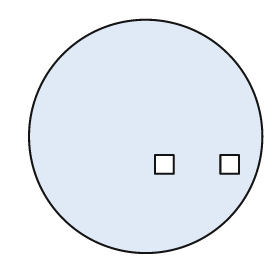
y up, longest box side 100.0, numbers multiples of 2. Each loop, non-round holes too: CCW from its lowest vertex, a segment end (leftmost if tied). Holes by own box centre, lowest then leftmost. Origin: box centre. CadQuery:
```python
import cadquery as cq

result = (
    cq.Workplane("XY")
    .moveTo(0.0, 0.0)
    .circle(50.0)
    .moveTo(4.0, -16.0)
    .lineTo(12.0, -16.0)
    .lineTo(12.0, -8.0)
    .lineTo(4.0, -8.0)
    .close()
    .moveTo(32.0, -16.0)
    .lineTo(40.0, -16.0)
    .lineTo(40.0, -8.0)
    .lineTo(32.0, -8.0)
    .close()
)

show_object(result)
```